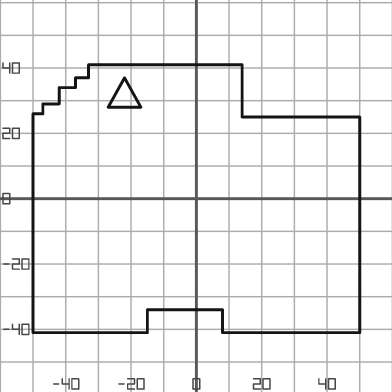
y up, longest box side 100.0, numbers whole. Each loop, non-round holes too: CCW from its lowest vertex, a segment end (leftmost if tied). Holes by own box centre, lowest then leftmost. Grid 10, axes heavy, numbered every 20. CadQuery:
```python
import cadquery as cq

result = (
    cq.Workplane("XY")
    .moveTo(-50.0, -41.0)
    .lineTo(-15.0, -41.0)
    .lineTo(-15.0, -34.0)
    .lineTo(8.0, -34.0)
    .lineTo(8.0, -41.0)
    .lineTo(50.0, -41.0)
    .lineTo(50.0, 25.0)
    .lineTo(14.0, 25.0)
    .lineTo(14.0, 41.0)
    .lineTo(-33.0, 41.0)
    .lineTo(-33.0, 37.0)
    .lineTo(-37.0, 37.0)
    .lineTo(-37.0, 34.0)
    .lineTo(-42.0, 34.0)
    .lineTo(-42.0, 29.0)
    .lineTo(-47.0, 29.0)
    .lineTo(-47.0, 26.0)
    .lineTo(-50.0, 26.0)
    .close()
    .moveTo(-27.0, 28.0)
    .lineTo(-17.0, 28.0)
    .lineTo(-22.0, 37.0)
    .close()
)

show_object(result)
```